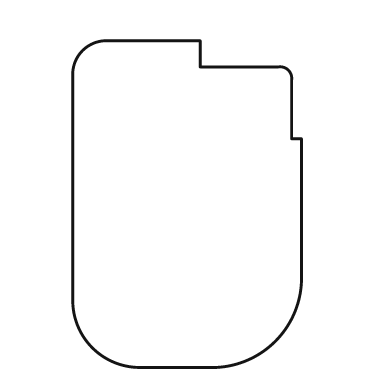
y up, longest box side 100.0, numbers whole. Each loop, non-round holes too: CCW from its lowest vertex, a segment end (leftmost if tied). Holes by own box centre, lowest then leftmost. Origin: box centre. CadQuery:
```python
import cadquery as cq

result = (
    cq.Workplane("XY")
    .moveTo(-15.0, -50.0)
    .lineTo(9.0, -50.0)
    .threePointArc((27.0, -42.0), (35.0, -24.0))
    .lineTo(35.0, 20.0)
    .lineTo(32.0, 20.0)
    .lineTo(32.0, 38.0)
    .threePointArc((31.0, 41.0), (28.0, 42.0))
    .lineTo(4.0, 42.0)
    .lineTo(4.0, 50.0)
    .lineTo(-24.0, 50.0)
    .threePointArc((-32.0, 47.0), (-35.0, 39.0))
    .lineTo(-35.0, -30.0)
    .threePointArc((-29.0, -44.0), (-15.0, -50.0))
    .close()
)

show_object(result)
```